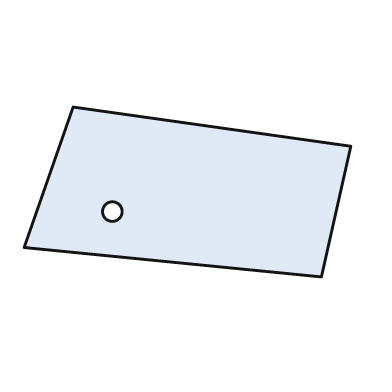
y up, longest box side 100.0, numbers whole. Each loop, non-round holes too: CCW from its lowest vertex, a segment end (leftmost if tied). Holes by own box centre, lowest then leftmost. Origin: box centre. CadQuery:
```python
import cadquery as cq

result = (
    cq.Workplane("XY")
    .moveTo(41.0, -26.0)
    .lineTo(50.0, 14.0)
    .lineTo(-35.0, 26.0)
    .lineTo(-50.0, -17.0)
    .close()
    .moveTo(-23.0, -6.0)
    .circle(3.0)
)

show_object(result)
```